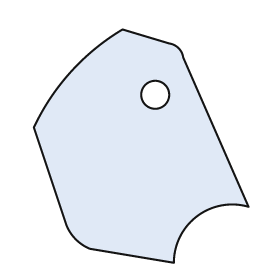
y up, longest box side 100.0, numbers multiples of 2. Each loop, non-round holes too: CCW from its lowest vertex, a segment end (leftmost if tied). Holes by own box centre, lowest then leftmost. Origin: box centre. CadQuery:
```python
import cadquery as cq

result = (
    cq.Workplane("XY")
    .moveTo(14.0, -50.0)
    .threePointArc((24.0, -30.0), (46.0, -26.0))
    .lineTo(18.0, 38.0)
    .threePointArc((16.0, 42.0), (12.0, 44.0))
    .lineTo(-8.0, 50.0)
    .threePointArc((-30.0, 32.0), (-46.0, 8.0))
    .lineTo(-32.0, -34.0)
    .threePointArc((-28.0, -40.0), (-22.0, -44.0))
    .close()
    .moveTo(6.0, 22.0)
    .circle(6.0)
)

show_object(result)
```